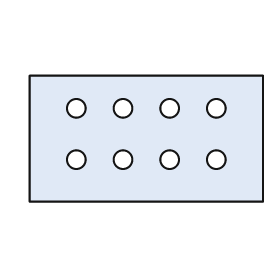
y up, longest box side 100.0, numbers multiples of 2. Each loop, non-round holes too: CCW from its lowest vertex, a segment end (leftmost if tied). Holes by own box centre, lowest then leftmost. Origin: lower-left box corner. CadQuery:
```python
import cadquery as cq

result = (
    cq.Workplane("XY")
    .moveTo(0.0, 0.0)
    .lineTo(100.0, 0.0)
    .lineTo(100.0, 54.0)
    .lineTo(0.0, 54.0)
    .close()
    .moveTo(20.0, 18.0)
    .circle(4.0)
    .moveTo(40.0, 18.0)
    .circle(4.0)
    .moveTo(60.0, 18.0)
    .circle(4.0)
    .moveTo(80.0, 18.0)
    .circle(4.0)
    .moveTo(20.0, 40.0)
    .circle(4.0)
    .moveTo(40.0, 40.0)
    .circle(4.0)
    .moveTo(60.0, 40.0)
    .circle(4.0)
    .moveTo(80.0, 40.0)
    .circle(4.0)
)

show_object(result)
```